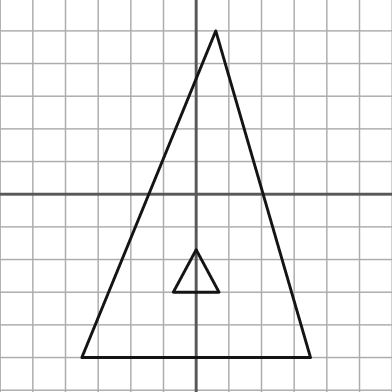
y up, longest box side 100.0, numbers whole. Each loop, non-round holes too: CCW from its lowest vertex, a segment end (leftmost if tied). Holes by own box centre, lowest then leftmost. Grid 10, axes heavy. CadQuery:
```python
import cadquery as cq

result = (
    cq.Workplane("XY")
    .moveTo(-35.0, -50.0)
    .lineTo(35.0, -50.0)
    .lineTo(6.0, 50.0)
    .close()
    .moveTo(-7.0, -30.0)
    .lineTo(7.0, -30.0)
    .lineTo(0.0, -17.0)
    .close()
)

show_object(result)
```